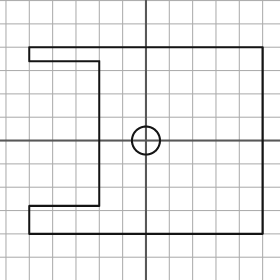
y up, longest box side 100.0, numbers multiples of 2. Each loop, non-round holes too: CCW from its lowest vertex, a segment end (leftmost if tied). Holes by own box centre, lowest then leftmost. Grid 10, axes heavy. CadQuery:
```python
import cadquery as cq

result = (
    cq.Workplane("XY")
    .moveTo(-50.0, -40.0)
    .lineTo(50.0, -40.0)
    .lineTo(50.0, 40.0)
    .lineTo(-50.0, 40.0)
    .lineTo(-50.0, 34.0)
    .lineTo(-20.0, 34.0)
    .lineTo(-20.0, -28.0)
    .lineTo(-50.0, -28.0)
    .close()
    .moveTo(0.0, 0.0)
    .circle(6.0)
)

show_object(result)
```